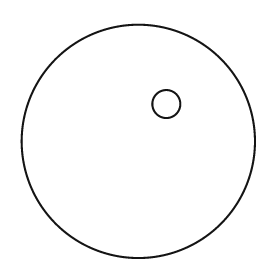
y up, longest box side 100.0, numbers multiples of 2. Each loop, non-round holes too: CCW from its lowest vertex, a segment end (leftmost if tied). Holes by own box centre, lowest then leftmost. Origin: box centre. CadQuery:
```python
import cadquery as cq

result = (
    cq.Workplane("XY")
    .moveTo(0.0, 0.0)
    .circle(50.0)
    .moveTo(12.0, 16.0)
    .circle(6.0)
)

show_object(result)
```